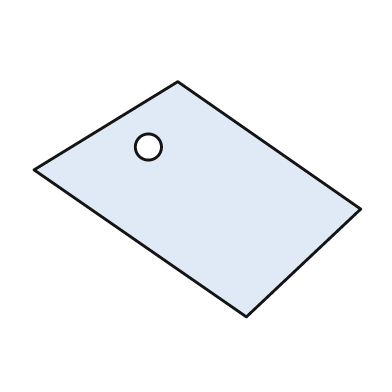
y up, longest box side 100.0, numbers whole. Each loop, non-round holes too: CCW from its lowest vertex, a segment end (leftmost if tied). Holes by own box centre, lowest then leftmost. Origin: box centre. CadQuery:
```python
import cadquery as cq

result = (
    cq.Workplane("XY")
    .moveTo(15.0, -36.0)
    .lineTo(50.0, -3.0)
    .lineTo(-6.0, 36.0)
    .lineTo(-50.0, 9.0)
    .close()
    .moveTo(-15.0, 16.0)
    .circle(4.0)
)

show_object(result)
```